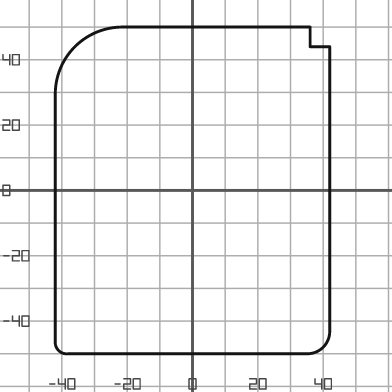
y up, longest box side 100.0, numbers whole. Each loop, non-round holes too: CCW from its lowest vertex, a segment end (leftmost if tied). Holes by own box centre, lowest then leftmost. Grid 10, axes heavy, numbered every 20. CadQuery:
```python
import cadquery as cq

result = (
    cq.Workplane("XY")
    .moveTo(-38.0, -50.0)
    .lineTo(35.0, -50.0)
    .threePointArc((40.0, -48.0), (42.0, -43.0))
    .lineTo(42.0, 44.0)
    .lineTo(36.0, 44.0)
    .lineTo(36.0, 50.0)
    .lineTo(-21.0, 50.0)
    .threePointArc((-36.0, 44.0), (-42.0, 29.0))
    .lineTo(-42.0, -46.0)
    .threePointArc((-41.0, -49.0), (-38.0, -50.0))
    .close()
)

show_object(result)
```